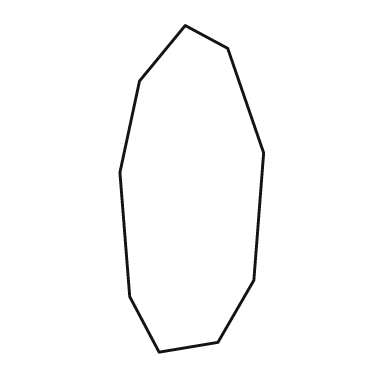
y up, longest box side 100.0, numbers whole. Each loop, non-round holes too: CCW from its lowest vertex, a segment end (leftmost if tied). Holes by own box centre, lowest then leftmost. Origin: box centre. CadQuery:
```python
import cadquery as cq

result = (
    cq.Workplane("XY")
    .moveTo(-10.0, -50.0)
    .lineTo(8.0, -47.0)
    .lineTo(19.0, -28.0)
    .lineTo(22.0, 11.0)
    .lineTo(11.0, 43.0)
    .lineTo(-2.0, 50.0)
    .lineTo(-16.0, 33.0)
    .lineTo(-22.0, 5.0)
    .lineTo(-19.0, -33.0)
    .close()
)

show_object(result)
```